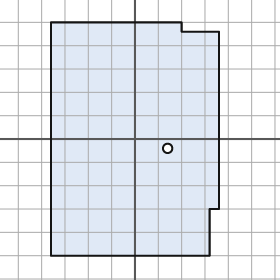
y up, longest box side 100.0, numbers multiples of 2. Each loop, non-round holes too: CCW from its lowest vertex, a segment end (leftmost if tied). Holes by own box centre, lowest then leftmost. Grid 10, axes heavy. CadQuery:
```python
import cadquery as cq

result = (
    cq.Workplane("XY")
    .moveTo(-36.0, -50.0)
    .lineTo(32.0, -50.0)
    .lineTo(32.0, -30.0)
    .lineTo(36.0, -30.0)
    .lineTo(36.0, 46.0)
    .lineTo(20.0, 46.0)
    .lineTo(20.0, 50.0)
    .lineTo(-36.0, 50.0)
    .close()
    .moveTo(14.0, -4.0)
    .circle(2.0)
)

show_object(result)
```